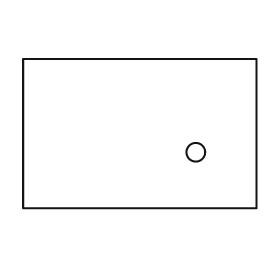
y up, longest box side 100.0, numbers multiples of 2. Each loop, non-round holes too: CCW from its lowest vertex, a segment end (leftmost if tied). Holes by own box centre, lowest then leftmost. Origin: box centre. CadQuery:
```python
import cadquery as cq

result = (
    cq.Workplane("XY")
    .moveTo(-50.0, -32.0)
    .lineTo(50.0, -32.0)
    .lineTo(50.0, 32.0)
    .lineTo(-50.0, 32.0)
    .close()
    .moveTo(24.0, -8.0)
    .circle(4.0)
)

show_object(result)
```